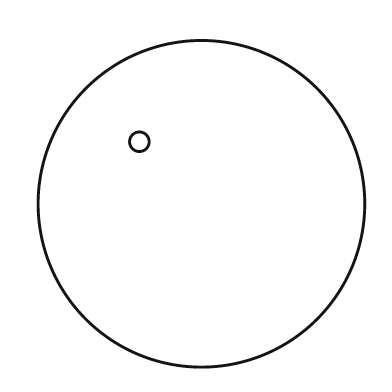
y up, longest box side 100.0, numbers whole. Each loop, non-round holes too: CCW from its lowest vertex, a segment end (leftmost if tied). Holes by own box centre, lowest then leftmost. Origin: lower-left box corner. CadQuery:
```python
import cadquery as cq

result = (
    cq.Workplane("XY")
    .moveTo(50.0, 50.0)
    .circle(50.0)
    .moveTo(31.0, 69.0)
    .circle(3.0)
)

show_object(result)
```